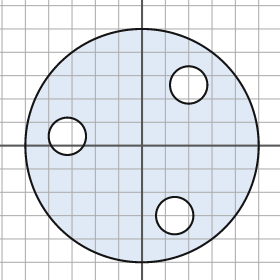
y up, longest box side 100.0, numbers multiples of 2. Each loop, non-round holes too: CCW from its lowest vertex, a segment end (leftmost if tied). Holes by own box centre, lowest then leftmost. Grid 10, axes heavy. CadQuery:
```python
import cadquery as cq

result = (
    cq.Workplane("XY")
    .moveTo(0.0, 0.0)
    .circle(50.0)
    .moveTo(14.0, -30.0)
    .circle(8.0)
    .moveTo(-32.0, 4.0)
    .circle(8.0)
    .moveTo(20.0, 26.0)
    .circle(8.0)
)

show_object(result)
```